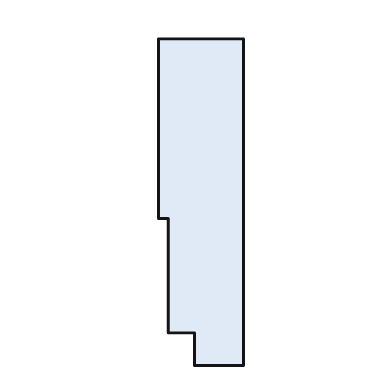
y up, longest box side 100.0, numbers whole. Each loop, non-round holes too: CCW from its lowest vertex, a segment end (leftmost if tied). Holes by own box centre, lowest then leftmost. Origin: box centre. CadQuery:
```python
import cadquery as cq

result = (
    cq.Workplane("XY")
    .moveTo(-2.0, -50.0)
    .lineTo(13.0, -50.0)
    .lineTo(13.0, 50.0)
    .lineTo(-13.0, 50.0)
    .lineTo(-13.0, -5.0)
    .lineTo(-10.0, -5.0)
    .lineTo(-10.0, -40.0)
    .lineTo(-2.0, -40.0)
    .close()
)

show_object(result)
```